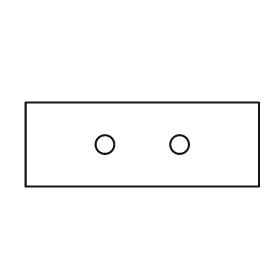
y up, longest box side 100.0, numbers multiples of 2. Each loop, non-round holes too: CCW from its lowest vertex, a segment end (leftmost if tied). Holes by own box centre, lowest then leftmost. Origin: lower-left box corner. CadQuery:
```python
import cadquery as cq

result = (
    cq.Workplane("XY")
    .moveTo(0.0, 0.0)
    .lineTo(100.0, 0.0)
    .lineTo(100.0, 36.0)
    .lineTo(0.0, 36.0)
    .close()
    .moveTo(34.0, 18.0)
    .circle(4.0)
    .moveTo(66.0, 18.0)
    .circle(4.0)
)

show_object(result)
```